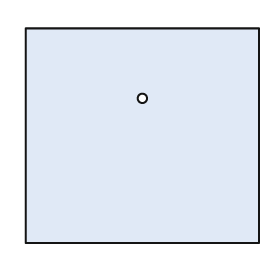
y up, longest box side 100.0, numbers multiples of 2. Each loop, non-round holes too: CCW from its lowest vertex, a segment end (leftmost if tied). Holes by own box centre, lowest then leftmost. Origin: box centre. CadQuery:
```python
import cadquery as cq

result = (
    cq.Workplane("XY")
    .moveTo(-50.0, -46.0)
    .lineTo(50.0, -46.0)
    .lineTo(50.0, 46.0)
    .lineTo(-50.0, 46.0)
    .close()
    .moveTo(0.0, 16.0)
    .circle(2.0)
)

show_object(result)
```